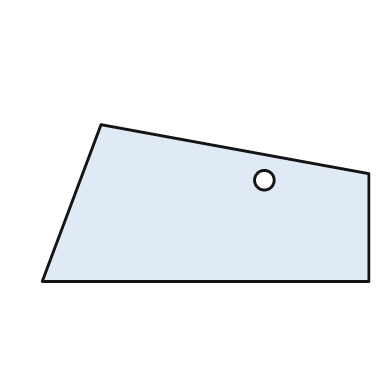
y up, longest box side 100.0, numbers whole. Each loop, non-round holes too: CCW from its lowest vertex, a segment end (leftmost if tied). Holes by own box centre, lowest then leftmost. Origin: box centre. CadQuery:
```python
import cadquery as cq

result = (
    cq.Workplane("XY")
    .moveTo(-50.0, -24.0)
    .lineTo(50.0, -24.0)
    .lineTo(50.0, 9.0)
    .lineTo(-32.0, 24.0)
    .close()
    .moveTo(18.0, 7.0)
    .circle(3.0)
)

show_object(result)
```